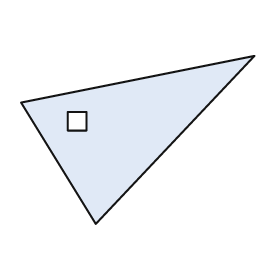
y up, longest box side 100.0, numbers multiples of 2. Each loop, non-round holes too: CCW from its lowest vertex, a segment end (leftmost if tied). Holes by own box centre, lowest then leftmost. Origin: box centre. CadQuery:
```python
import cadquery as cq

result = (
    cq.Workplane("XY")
    .moveTo(-18.0, -36.0)
    .lineTo(50.0, 36.0)
    .lineTo(-50.0, 16.0)
    .close()
    .moveTo(-30.0, 4.0)
    .lineTo(-22.0, 4.0)
    .lineTo(-22.0, 12.0)
    .lineTo(-30.0, 12.0)
    .close()
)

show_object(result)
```